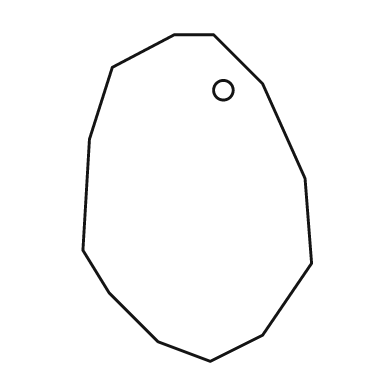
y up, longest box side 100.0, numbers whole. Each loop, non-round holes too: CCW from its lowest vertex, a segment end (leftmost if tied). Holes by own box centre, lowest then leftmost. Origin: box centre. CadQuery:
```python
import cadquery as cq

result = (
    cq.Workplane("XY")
    .moveTo(4.0, -50.0)
    .lineTo(20.0, -42.0)
    .lineTo(35.0, -20.0)
    .lineTo(33.0, 6.0)
    .lineTo(20.0, 35.0)
    .lineTo(5.0, 50.0)
    .lineTo(-7.0, 50.0)
    .lineTo(-26.0, 40.0)
    .lineTo(-33.0, 18.0)
    .lineTo(-35.0, -16.0)
    .lineTo(-27.0, -29.0)
    .lineTo(-12.0, -44.0)
    .close()
    .moveTo(8.0, 33.0)
    .circle(3.0)
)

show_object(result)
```